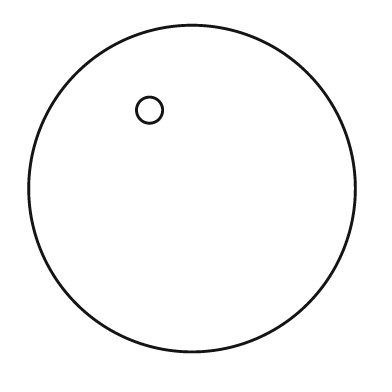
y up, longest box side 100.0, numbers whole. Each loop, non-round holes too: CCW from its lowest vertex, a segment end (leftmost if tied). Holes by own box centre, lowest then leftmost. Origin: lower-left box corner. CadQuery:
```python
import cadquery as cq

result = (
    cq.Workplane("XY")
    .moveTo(50.0, 50.0)
    .circle(50.0)
    .moveTo(37.0, 74.0)
    .circle(4.0)
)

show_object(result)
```